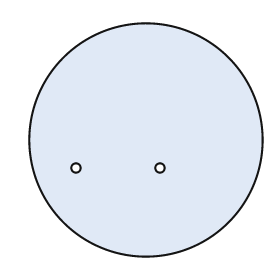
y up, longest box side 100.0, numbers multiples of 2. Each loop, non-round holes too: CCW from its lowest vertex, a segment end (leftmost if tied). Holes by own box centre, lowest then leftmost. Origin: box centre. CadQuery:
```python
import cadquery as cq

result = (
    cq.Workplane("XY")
    .moveTo(0.0, 0.0)
    .circle(50.0)
    .moveTo(-30.0, -12.0)
    .circle(2.0)
    .moveTo(6.0, -12.0)
    .circle(2.0)
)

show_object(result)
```